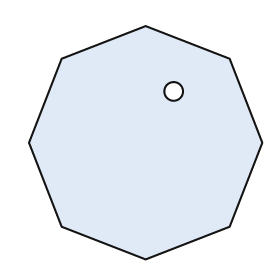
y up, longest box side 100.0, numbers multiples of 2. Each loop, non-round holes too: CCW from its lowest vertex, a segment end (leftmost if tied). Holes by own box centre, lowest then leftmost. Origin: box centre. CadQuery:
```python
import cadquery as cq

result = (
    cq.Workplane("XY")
    .moveTo(0.0, -50.0)
    .lineTo(36.0, -36.0)
    .lineTo(50.0, 0.0)
    .lineTo(36.0, 36.0)
    .lineTo(0.0, 50.0)
    .lineTo(-36.0, 36.0)
    .lineTo(-50.0, 0.0)
    .lineTo(-36.0, -36.0)
    .close()
    .moveTo(12.0, 22.0)
    .circle(4.0)
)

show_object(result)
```